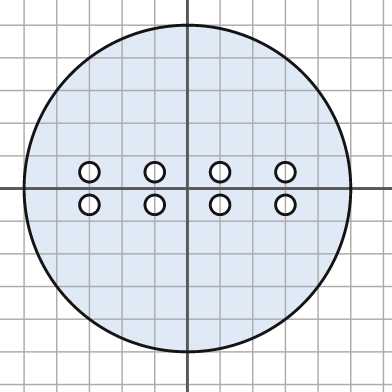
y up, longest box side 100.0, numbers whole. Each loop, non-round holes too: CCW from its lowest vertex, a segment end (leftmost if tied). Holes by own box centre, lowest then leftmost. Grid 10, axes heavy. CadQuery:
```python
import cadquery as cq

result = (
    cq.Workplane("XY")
    .moveTo(0.0, 0.0)
    .circle(50.0)
    .moveTo(-30.0, -5.0)
    .circle(3.0)
    .moveTo(-10.0, -5.0)
    .circle(3.0)
    .moveTo(10.0, -5.0)
    .circle(3.0)
    .moveTo(30.0, -5.0)
    .circle(3.0)
    .moveTo(-30.0, 5.0)
    .circle(3.0)
    .moveTo(-10.0, 5.0)
    .circle(3.0)
    .moveTo(10.0, 5.0)
    .circle(3.0)
    .moveTo(30.0, 5.0)
    .circle(3.0)
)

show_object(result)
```